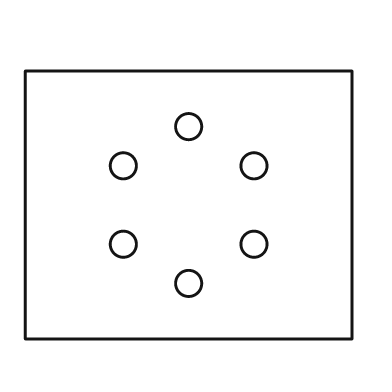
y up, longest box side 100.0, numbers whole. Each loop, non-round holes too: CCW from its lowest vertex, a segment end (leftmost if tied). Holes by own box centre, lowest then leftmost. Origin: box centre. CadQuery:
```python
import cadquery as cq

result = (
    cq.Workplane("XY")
    .moveTo(-50.0, -41.0)
    .lineTo(50.0, -41.0)
    .lineTo(50.0, 41.0)
    .lineTo(-50.0, 41.0)
    .close()
    .moveTo(0.0, -24.0)
    .circle(4.0)
    .moveTo(-20.0, -12.0)
    .circle(4.0)
    .moveTo(20.0, -12.0)
    .circle(4.0)
    .moveTo(-20.0, 12.0)
    .circle(4.0)
    .moveTo(20.0, 12.0)
    .circle(4.0)
    .moveTo(0.0, 24.0)
    .circle(4.0)
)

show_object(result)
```